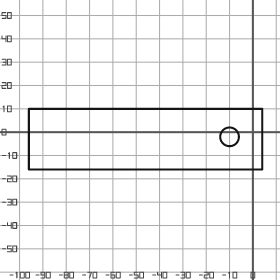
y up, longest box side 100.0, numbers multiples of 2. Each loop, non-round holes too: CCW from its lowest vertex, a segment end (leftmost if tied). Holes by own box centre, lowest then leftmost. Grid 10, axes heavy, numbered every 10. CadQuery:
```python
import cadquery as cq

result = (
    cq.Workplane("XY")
    .moveTo(-96.0, -16.0)
    .lineTo(4.0, -16.0)
    .lineTo(4.0, 10.0)
    .lineTo(-96.0, 10.0)
    .close()
    .moveTo(-10.0, -2.0)
    .circle(4.0)
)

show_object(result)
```